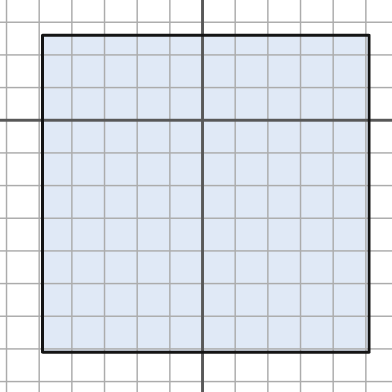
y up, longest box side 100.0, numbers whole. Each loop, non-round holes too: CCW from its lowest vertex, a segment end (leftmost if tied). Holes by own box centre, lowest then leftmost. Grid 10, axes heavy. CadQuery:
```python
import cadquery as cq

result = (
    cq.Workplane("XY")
    .moveTo(-49.0, -71.0)
    .lineTo(51.0, -71.0)
    .lineTo(51.0, 26.0)
    .lineTo(-49.0, 26.0)
    .close()
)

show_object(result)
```